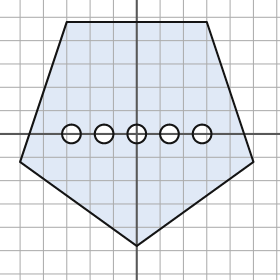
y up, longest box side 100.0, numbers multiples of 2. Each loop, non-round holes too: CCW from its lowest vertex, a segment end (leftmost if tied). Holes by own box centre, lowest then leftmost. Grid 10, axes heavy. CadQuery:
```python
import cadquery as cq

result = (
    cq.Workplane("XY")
    .moveTo(0.0, -48.0)
    .lineTo(50.0, -12.0)
    .lineTo(30.0, 48.0)
    .lineTo(-30.0, 48.0)
    .lineTo(-50.0, -12.0)
    .close()
    .moveTo(-28.0, 0.0)
    .circle(4.0)
    .moveTo(-14.0, 0.0)
    .circle(4.0)
    .moveTo(0.0, 0.0)
    .circle(4.0)
    .moveTo(14.0, 0.0)
    .circle(4.0)
    .moveTo(28.0, 0.0)
    .circle(4.0)
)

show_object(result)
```